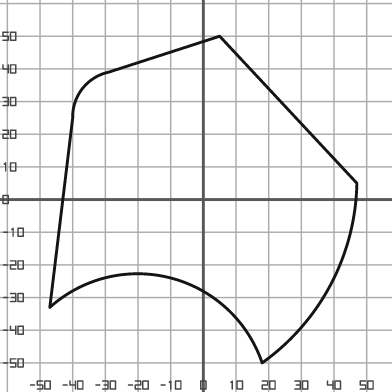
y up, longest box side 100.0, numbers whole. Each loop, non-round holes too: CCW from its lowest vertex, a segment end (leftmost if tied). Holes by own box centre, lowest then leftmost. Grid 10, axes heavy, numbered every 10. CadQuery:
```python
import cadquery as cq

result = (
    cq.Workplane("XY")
    .moveTo(18.0, -50.0)
    .threePointArc((39.0, -26.0), (47.0, 5.0))
    .lineTo(5.0, 50.0)
    .lineTo(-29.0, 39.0)
    .threePointArc((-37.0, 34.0), (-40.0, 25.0))
    .lineTo(-47.0, -33.0)
    .threePointArc((-10.0, -24.0), (18.0, -50.0))
    .close()
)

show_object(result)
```